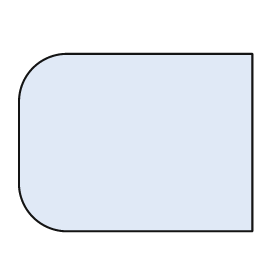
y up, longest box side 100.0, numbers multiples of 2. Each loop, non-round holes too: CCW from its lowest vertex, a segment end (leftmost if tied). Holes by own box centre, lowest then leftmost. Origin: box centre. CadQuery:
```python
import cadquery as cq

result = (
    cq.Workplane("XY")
    .moveTo(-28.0, -38.0)
    .lineTo(50.0, -38.0)
    .lineTo(50.0, 38.0)
    .lineTo(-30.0, 38.0)
    .threePointArc((-44.0, 32.0), (-50.0, 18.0))
    .lineTo(-50.0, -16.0)
    .threePointArc((-44.0, -32.0), (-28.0, -38.0))
    .close()
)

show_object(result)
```